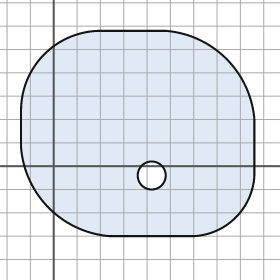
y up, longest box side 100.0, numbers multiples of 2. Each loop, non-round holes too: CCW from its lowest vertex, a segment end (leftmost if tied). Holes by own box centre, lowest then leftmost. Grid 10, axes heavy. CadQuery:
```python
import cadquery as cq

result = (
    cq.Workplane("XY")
    .moveTo(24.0, -30.0)
    .lineTo(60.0, -30.0)
    .threePointArc((78.0, -22.0), (86.0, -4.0))
    .lineTo(86.0, 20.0)
    .threePointArc((74.0, 46.0), (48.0, 58.0))
    .lineTo(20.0, 58.0)
    .threePointArc((-4.0, 48.0), (-14.0, 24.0))
    .lineTo(-14.0, 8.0)
    .threePointArc((-2.0, -18.0), (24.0, -30.0))
    .close()
    .moveTo(42.0, -4.0)
    .circle(6.0)
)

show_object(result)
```